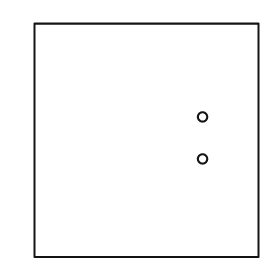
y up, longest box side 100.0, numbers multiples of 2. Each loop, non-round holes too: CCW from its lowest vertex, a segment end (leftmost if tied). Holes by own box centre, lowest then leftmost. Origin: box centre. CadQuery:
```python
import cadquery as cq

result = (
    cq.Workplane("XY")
    .moveTo(-48.0, -50.0)
    .lineTo(48.0, -50.0)
    .lineTo(48.0, 50.0)
    .lineTo(-48.0, 50.0)
    .close()
    .moveTo(24.0, -8.0)
    .circle(2.0)
    .moveTo(24.0, 10.0)
    .circle(2.0)
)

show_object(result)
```